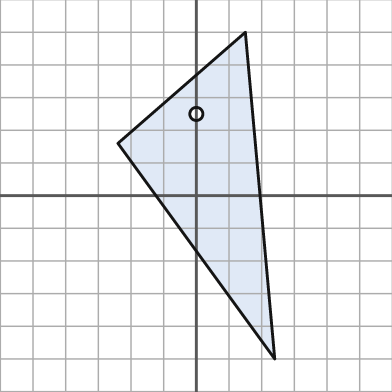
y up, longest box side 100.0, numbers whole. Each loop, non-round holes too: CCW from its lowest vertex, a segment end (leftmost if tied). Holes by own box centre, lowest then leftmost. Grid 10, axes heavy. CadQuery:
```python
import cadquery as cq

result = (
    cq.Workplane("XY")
    .moveTo(24.0, -50.0)
    .lineTo(15.0, 50.0)
    .lineTo(-24.0, 16.0)
    .close()
    .moveTo(0.0, 25.0)
    .circle(2.0)
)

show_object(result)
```